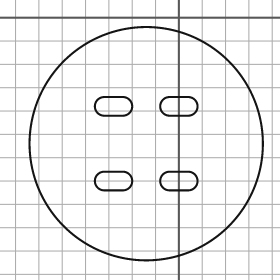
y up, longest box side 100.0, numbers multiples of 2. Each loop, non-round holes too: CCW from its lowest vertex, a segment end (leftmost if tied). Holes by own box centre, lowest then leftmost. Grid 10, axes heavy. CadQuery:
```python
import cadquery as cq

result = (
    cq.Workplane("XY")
    .moveTo(-14.0, -54.0)
    .circle(50.0)
    .moveTo(-32.0, -74.0)
    .lineTo(-24.0, -74.0)
    .threePointArc((-20.0, -70.0), (-24.0, -66.0))
    .lineTo(-32.0, -66.0)
    .threePointArc((-36.0, -70.0), (-32.0, -74.0))
    .close()
    .moveTo(-4.0, -74.0)
    .lineTo(4.0, -74.0)
    .threePointArc((8.0, -70.0), (4.0, -66.0))
    .lineTo(-4.0, -66.0)
    .threePointArc((-8.0, -70.0), (-4.0, -74.0))
    .close()
    .moveTo(-32.0, -42.0)
    .lineTo(-24.0, -42.0)
    .threePointArc((-20.0, -38.0), (-24.0, -34.0))
    .lineTo(-32.0, -34.0)
    .threePointArc((-36.0, -38.0), (-32.0, -42.0))
    .close()
    .moveTo(-4.0, -42.0)
    .lineTo(4.0, -42.0)
    .threePointArc((8.0, -38.0), (4.0, -34.0))
    .lineTo(-4.0, -34.0)
    .threePointArc((-8.0, -38.0), (-4.0, -42.0))
    .close()
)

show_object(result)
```